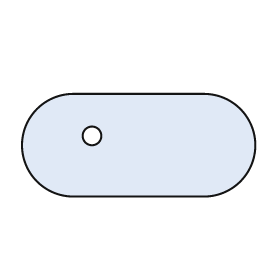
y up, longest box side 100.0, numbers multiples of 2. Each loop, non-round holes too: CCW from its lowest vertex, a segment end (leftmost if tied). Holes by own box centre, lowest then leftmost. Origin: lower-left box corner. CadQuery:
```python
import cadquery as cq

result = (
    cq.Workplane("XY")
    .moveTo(22.0, 0.0)
    .lineTo(78.0, 0.0)
    .threePointArc((100.0, 22.0), (78.0, 44.0))
    .lineTo(22.0, 44.0)
    .threePointArc((0.0, 22.0), (22.0, 0.0))
    .close()
    .moveTo(30.0, 26.0)
    .circle(4.0)
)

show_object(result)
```